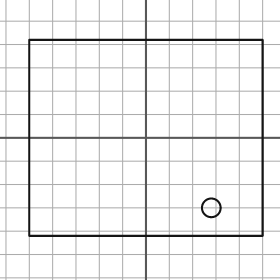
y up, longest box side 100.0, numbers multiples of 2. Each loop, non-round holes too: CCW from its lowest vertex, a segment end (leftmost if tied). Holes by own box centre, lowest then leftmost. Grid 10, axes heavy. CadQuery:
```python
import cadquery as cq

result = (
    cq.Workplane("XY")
    .moveTo(-50.0, -42.0)
    .lineTo(50.0, -42.0)
    .lineTo(50.0, 42.0)
    .lineTo(-50.0, 42.0)
    .close()
    .moveTo(28.0, -30.0)
    .circle(4.0)
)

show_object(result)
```